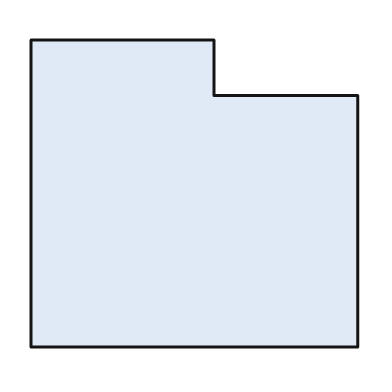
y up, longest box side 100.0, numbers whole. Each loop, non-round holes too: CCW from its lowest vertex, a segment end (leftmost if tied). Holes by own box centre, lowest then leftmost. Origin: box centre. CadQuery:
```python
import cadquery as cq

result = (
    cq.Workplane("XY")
    .moveTo(-50.0, -47.0)
    .lineTo(50.0, -47.0)
    .lineTo(50.0, 30.0)
    .lineTo(6.0, 30.0)
    .lineTo(6.0, 47.0)
    .lineTo(-50.0, 47.0)
    .close()
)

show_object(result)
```